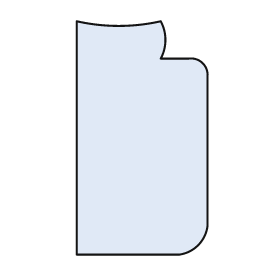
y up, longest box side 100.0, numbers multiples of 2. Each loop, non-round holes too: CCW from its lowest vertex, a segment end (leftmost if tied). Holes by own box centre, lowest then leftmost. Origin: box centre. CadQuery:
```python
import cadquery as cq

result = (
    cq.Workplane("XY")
    .moveTo(-28.0, -50.0)
    .lineTo(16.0, -50.0)
    .threePointArc((24.0, -46.0), (28.0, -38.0))
    .lineTo(28.0, 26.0)
    .threePointArc((26.0, 32.0), (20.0, 34.0))
    .lineTo(8.0, 34.0)
    .threePointArc((10.0, 42.0), (8.0, 50.0))
    .threePointArc((-10.0, 48.0), (-28.0, 50.0))
    .close()
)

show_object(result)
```